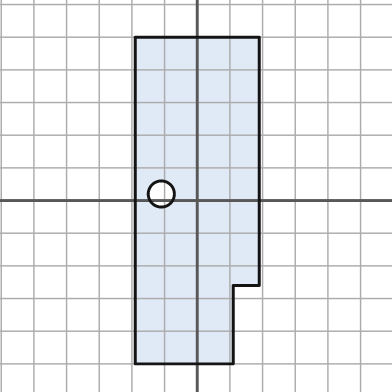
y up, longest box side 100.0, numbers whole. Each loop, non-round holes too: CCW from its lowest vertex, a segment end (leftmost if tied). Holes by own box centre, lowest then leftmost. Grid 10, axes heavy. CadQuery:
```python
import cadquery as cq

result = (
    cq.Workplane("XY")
    .moveTo(-19.0, -50.0)
    .lineTo(11.0, -50.0)
    .lineTo(11.0, -26.0)
    .lineTo(19.0, -26.0)
    .lineTo(19.0, 50.0)
    .lineTo(-19.0, 50.0)
    .close()
    .moveTo(-11.0, 2.0)
    .circle(4.0)
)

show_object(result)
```